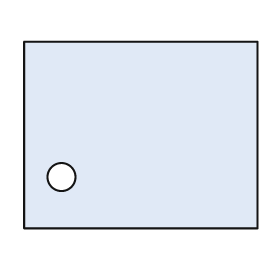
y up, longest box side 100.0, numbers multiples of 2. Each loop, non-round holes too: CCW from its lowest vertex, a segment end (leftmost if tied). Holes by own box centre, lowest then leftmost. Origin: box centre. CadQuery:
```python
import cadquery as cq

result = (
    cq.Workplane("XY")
    .moveTo(-50.0, -40.0)
    .lineTo(50.0, -40.0)
    .lineTo(50.0, 40.0)
    .lineTo(-50.0, 40.0)
    .close()
    .moveTo(-34.0, -18.0)
    .circle(6.0)
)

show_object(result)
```